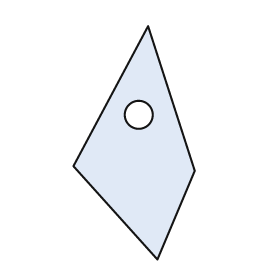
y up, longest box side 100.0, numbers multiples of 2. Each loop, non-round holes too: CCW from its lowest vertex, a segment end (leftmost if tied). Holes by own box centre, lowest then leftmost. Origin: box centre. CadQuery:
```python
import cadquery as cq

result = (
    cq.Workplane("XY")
    .moveTo(10.0, -50.0)
    .lineTo(26.0, -12.0)
    .lineTo(6.0, 50.0)
    .lineTo(-26.0, -10.0)
    .close()
    .moveTo(2.0, 12.0)
    .circle(6.0)
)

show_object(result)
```